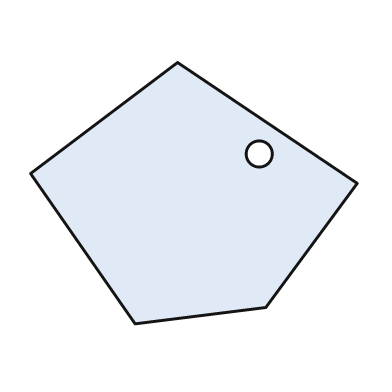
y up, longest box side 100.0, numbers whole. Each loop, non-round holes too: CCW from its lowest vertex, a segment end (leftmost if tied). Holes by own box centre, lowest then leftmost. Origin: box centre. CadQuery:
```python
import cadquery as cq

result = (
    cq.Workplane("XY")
    .moveTo(-18.0, -40.0)
    .lineTo(22.0, -35.0)
    .lineTo(50.0, 3.0)
    .lineTo(-5.0, 40.0)
    .lineTo(-50.0, 6.0)
    .close()
    .moveTo(20.0, 12.0)
    .circle(4.0)
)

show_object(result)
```